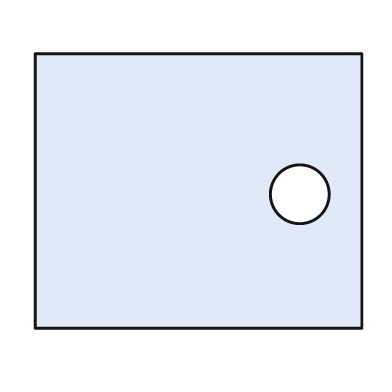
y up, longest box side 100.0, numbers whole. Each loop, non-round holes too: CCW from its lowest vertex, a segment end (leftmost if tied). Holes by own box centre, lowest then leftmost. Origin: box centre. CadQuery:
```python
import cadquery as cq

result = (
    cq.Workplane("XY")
    .moveTo(-50.0, -42.0)
    .lineTo(50.0, -42.0)
    .lineTo(50.0, 42.0)
    .lineTo(-50.0, 42.0)
    .close()
    .moveTo(31.0, -1.0)
    .circle(9.0)
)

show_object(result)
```